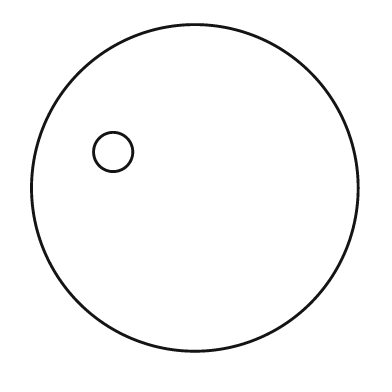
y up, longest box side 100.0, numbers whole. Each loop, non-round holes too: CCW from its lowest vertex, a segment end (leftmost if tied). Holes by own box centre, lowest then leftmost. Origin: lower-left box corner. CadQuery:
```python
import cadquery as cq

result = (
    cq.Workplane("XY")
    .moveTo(50.0, 50.0)
    .circle(50.0)
    .moveTo(25.0, 61.0)
    .circle(6.0)
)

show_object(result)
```